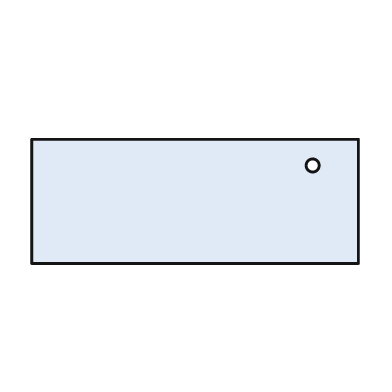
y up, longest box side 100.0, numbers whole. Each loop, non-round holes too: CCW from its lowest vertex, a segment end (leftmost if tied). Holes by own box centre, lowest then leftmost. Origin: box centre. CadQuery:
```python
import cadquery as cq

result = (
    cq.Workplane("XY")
    .moveTo(-50.0, -19.0)
    .lineTo(50.0, -19.0)
    .lineTo(50.0, 19.0)
    .lineTo(-50.0, 19.0)
    .close()
    .moveTo(36.0, 11.0)
    .circle(2.0)
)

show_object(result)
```